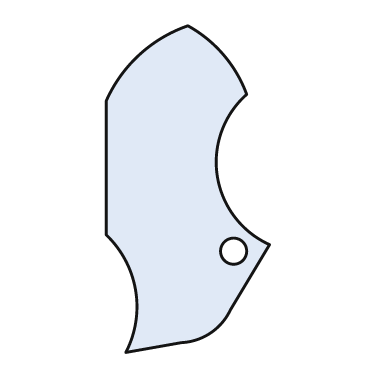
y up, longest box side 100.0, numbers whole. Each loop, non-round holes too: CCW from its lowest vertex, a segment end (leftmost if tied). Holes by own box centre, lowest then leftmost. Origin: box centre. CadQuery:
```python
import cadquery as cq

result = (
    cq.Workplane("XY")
    .moveTo(-19.0, -50.0)
    .lineTo(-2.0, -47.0)
    .threePointArc((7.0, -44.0), (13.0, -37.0))
    .lineTo(25.0, -17.0)
    .threePointArc((9.0, 4.0), (18.0, 29.0))
    .threePointArc((11.0, 41.0), (0.0, 50.0))
    .threePointArc((-15.0, 41.0), (-25.0, 27.0))
    .lineTo(-25.0, -14.0)
    .threePointArc((-16.0, -31.0), (-19.0, -50.0))
    .close()
    .moveTo(14.0, -19.0)
    .circle(4.0)
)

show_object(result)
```